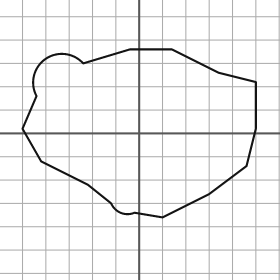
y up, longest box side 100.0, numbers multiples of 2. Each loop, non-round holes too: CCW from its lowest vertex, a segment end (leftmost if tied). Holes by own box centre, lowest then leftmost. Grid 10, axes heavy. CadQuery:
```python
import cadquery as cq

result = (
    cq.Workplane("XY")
    .moveTo(10.0, -36.0)
    .lineTo(30.0, -26.0)
    .lineTo(46.0, -14.0)
    .lineTo(50.0, 2.0)
    .lineTo(50.0, 22.0)
    .lineTo(34.0, 26.0)
    .lineTo(14.0, 36.0)
    .lineTo(-4.0, 36.0)
    .lineTo(-24.0, 30.0)
    .threePointArc((-40.0, 32.0), (-44.0, 16.0))
    .lineTo(-50.0, 2.0)
    .lineTo(-42.0, -12.0)
    .lineTo(-22.0, -22.0)
    .lineTo(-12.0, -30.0)
    .threePointArc((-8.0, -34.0), (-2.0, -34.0))
    .close()
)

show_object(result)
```